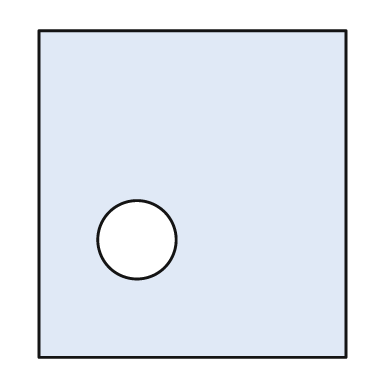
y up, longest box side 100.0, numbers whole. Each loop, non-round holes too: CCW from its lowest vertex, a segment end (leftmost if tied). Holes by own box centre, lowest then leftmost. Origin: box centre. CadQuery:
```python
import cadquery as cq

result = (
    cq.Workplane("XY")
    .moveTo(-47.0, -50.0)
    .lineTo(47.0, -50.0)
    .lineTo(47.0, 50.0)
    .lineTo(-47.0, 50.0)
    .close()
    .moveTo(-17.0, -14.0)
    .circle(12.0)
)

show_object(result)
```